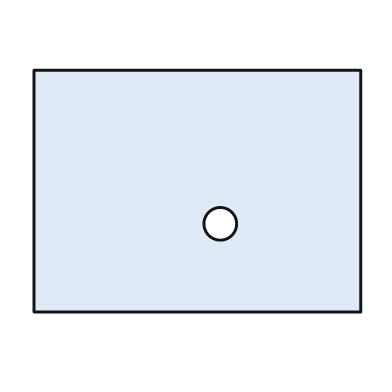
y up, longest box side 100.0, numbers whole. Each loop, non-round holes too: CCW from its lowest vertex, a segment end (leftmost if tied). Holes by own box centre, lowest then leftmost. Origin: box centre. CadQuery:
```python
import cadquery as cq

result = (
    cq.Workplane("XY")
    .moveTo(-50.0, -37.0)
    .lineTo(50.0, -37.0)
    .lineTo(50.0, 37.0)
    .lineTo(-50.0, 37.0)
    .close()
    .moveTo(7.0, -10.0)
    .circle(5.0)
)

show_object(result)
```